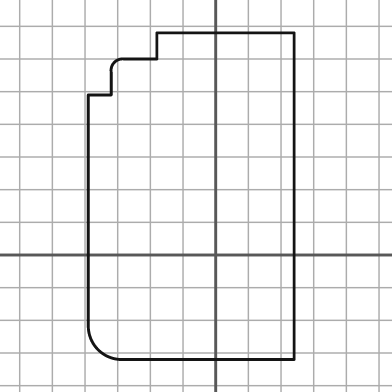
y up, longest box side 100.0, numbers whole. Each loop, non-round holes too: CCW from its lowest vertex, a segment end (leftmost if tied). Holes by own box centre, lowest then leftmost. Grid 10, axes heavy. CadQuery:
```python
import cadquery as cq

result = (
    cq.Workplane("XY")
    .moveTo(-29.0, -32.0)
    .lineTo(24.0, -32.0)
    .lineTo(24.0, 68.0)
    .lineTo(-18.0, 68.0)
    .lineTo(-18.0, 60.0)
    .lineTo(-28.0, 60.0)
    .threePointArc((-31.0, 59.0), (-32.0, 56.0))
    .lineTo(-32.0, 49.0)
    .lineTo(-39.0, 49.0)
    .lineTo(-39.0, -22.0)
    .threePointArc((-36.0, -29.0), (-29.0, -32.0))
    .close()
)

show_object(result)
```